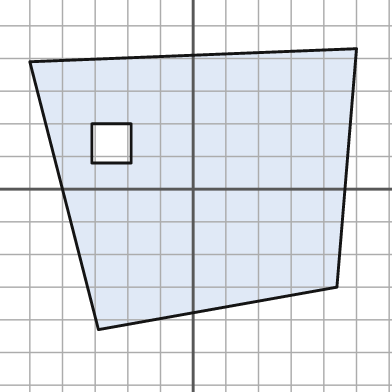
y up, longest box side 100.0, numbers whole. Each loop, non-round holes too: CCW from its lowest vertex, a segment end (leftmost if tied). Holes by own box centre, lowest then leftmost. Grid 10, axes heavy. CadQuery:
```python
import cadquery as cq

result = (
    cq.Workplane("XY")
    .moveTo(-29.0, -43.0)
    .lineTo(44.0, -30.0)
    .lineTo(50.0, 43.0)
    .lineTo(-50.0, 39.0)
    .close()
    .moveTo(-31.0, 8.0)
    .lineTo(-19.0, 8.0)
    .lineTo(-19.0, 20.0)
    .lineTo(-31.0, 20.0)
    .close()
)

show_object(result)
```